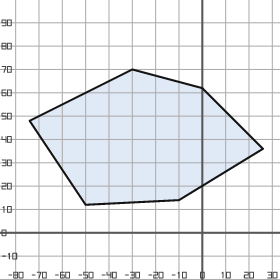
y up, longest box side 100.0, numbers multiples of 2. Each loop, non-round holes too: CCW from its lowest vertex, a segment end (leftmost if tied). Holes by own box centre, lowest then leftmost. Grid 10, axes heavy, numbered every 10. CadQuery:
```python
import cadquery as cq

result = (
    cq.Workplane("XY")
    .moveTo(-50.0, 12.0)
    .lineTo(-10.0, 14.0)
    .lineTo(26.0, 36.0)
    .lineTo(0.0, 62.0)
    .lineTo(-30.0, 70.0)
    .lineTo(-74.0, 48.0)
    .close()
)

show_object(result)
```